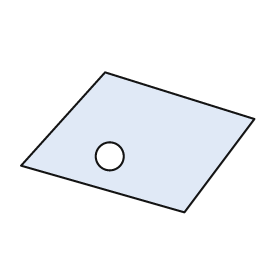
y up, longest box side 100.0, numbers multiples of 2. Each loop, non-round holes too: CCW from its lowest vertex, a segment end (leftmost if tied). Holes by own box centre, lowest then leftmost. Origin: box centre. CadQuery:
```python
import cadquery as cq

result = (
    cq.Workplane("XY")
    .moveTo(20.0, -30.0)
    .lineTo(50.0, 10.0)
    .lineTo(-14.0, 30.0)
    .lineTo(-50.0, -10.0)
    .close()
    .moveTo(-12.0, -6.0)
    .circle(6.0)
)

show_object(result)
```